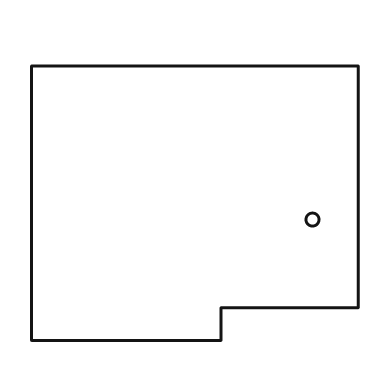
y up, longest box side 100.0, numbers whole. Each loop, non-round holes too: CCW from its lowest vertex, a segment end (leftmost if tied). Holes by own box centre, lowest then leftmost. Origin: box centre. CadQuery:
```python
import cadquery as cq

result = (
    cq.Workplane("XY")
    .moveTo(-50.0, -42.0)
    .lineTo(8.0, -42.0)
    .lineTo(8.0, -32.0)
    .lineTo(50.0, -32.0)
    .lineTo(50.0, 42.0)
    .lineTo(-50.0, 42.0)
    .close()
    .moveTo(36.0, -5.0)
    .circle(2.0)
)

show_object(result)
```